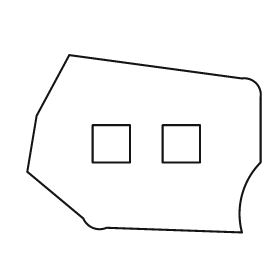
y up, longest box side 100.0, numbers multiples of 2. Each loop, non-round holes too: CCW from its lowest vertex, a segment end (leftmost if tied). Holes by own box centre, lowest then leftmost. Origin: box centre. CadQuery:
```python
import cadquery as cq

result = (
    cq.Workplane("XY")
    .moveTo(42.0, -38.0)
    .threePointArc((42.0, -22.0), (50.0, -8.0))
    .lineTo(50.0, 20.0)
    .threePointArc((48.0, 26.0), (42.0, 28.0))
    .lineTo(-32.0, 38.0)
    .lineTo(-46.0, 12.0)
    .lineTo(-50.0, -12.0)
    .lineTo(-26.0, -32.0)
    .threePointArc((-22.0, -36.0), (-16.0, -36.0))
    .close()
    .moveTo(-22.0, -8.0)
    .lineTo(-6.0, -8.0)
    .lineTo(-6.0, 8.0)
    .lineTo(-22.0, 8.0)
    .close()
    .moveTo(8.0, -8.0)
    .lineTo(24.0, -8.0)
    .lineTo(24.0, 8.0)
    .lineTo(8.0, 8.0)
    .close()
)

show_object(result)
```